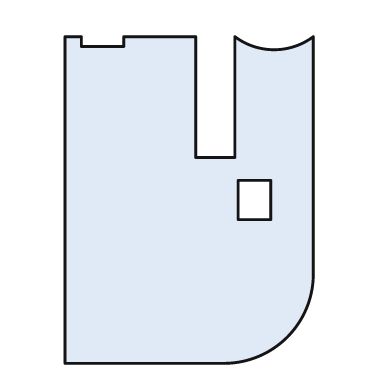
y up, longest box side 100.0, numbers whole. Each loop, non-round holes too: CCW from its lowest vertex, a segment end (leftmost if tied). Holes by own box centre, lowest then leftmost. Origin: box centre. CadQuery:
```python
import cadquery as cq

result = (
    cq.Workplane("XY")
    .moveTo(-38.0, -50.0)
    .lineTo(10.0, -50.0)
    .threePointArc((30.0, -42.0), (38.0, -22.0))
    .lineTo(38.0, 50.0)
    .threePointArc((26.0, 46.0), (14.0, 50.0))
    .lineTo(14.0, 13.0)
    .lineTo(2.0, 13.0)
    .lineTo(2.0, 50.0)
    .lineTo(-20.0, 50.0)
    .lineTo(-20.0, 47.0)
    .lineTo(-33.0, 47.0)
    .lineTo(-33.0, 50.0)
    .lineTo(-38.0, 50.0)
    .close()
    .moveTo(15.0, -6.0)
    .lineTo(25.0, -6.0)
    .lineTo(25.0, 6.0)
    .lineTo(15.0, 6.0)
    .close()
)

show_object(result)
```